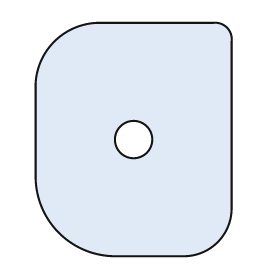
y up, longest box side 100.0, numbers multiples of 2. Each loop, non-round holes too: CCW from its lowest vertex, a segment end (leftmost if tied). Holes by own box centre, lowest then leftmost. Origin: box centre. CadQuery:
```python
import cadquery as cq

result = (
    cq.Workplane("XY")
    .moveTo(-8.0, -50.0)
    .lineTo(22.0, -50.0)
    .threePointArc((36.0, -44.0), (42.0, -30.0))
    .lineTo(42.0, 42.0)
    .threePointArc((40.0, 48.0), (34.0, 50.0))
    .lineTo(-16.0, 50.0)
    .threePointArc((-34.0, 42.0), (-42.0, 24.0))
    .lineTo(-42.0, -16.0)
    .threePointArc((-32.0, -40.0), (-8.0, -50.0))
    .close()
    .moveTo(0.0, 0.0)
    .circle(8.0)
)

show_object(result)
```